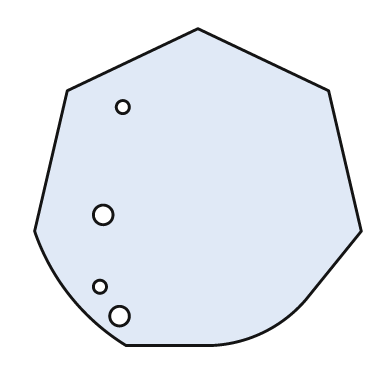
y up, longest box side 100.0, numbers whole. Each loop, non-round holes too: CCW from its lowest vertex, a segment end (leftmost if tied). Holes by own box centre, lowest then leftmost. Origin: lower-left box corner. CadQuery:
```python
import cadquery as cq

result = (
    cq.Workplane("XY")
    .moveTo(28.0, 0.0)
    .lineTo(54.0, 0.0)
    .threePointArc((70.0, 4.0), (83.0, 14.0))
    .lineTo(100.0, 35.0)
    .lineTo(90.0, 78.0)
    .lineTo(50.0, 97.0)
    .lineTo(10.0, 78.0)
    .lineTo(0.0, 35.0)
    .threePointArc((11.0, 15.0), (28.0, 0.0))
    .close()
    .moveTo(26.0, 9.0)
    .circle(3.0)
    .moveTo(20.0, 18.0)
    .circle(2.0)
    .moveTo(21.0, 40.0)
    .circle(3.0)
    .moveTo(27.0, 73.0)
    .circle(2.0)
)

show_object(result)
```